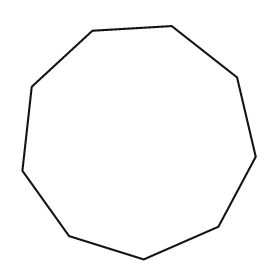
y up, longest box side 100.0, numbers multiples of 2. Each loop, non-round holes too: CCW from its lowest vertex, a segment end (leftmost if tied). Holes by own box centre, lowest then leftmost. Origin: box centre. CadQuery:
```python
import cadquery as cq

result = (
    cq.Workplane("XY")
    .moveTo(2.0, -50.0)
    .lineTo(34.0, -36.0)
    .lineTo(50.0, -6.0)
    .lineTo(42.0, 28.0)
    .lineTo(14.0, 50.0)
    .lineTo(-20.0, 48.0)
    .lineTo(-46.0, 24.0)
    .lineTo(-50.0, -12.0)
    .lineTo(-30.0, -40.0)
    .close()
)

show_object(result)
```